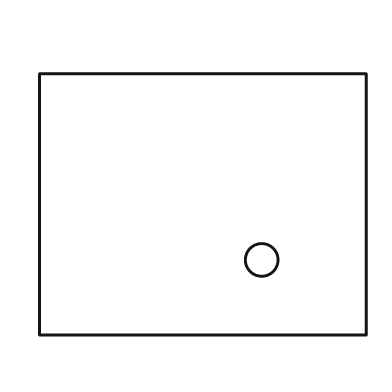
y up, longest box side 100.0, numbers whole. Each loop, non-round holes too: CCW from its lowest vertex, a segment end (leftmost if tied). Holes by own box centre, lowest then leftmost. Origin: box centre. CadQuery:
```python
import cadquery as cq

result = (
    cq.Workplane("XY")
    .moveTo(-50.0, -40.0)
    .lineTo(50.0, -40.0)
    .lineTo(50.0, 40.0)
    .lineTo(-50.0, 40.0)
    .close()
    .moveTo(18.0, -17.0)
    .circle(5.0)
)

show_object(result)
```